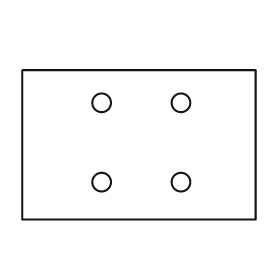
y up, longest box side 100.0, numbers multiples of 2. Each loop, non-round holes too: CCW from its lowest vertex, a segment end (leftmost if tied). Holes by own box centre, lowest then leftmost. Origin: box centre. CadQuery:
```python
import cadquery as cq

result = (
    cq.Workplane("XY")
    .moveTo(-50.0, -32.0)
    .lineTo(50.0, -32.0)
    .lineTo(50.0, 32.0)
    .lineTo(-50.0, 32.0)
    .close()
    .moveTo(-16.0, -16.0)
    .circle(4.0)
    .moveTo(18.0, -16.0)
    .circle(4.0)
    .moveTo(-16.0, 18.0)
    .circle(4.0)
    .moveTo(18.0, 18.0)
    .circle(4.0)
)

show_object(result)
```